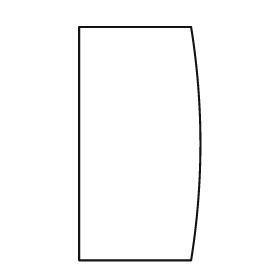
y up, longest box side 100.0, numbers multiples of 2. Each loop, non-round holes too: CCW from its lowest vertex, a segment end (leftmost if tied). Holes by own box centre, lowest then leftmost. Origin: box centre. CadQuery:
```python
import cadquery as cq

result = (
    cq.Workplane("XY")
    .moveTo(-26.0, -50.0)
    .lineTo(22.0, -50.0)
    .threePointArc((26.0, 0.0), (22.0, 50.0))
    .lineTo(-26.0, 50.0)
    .close()
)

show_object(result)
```